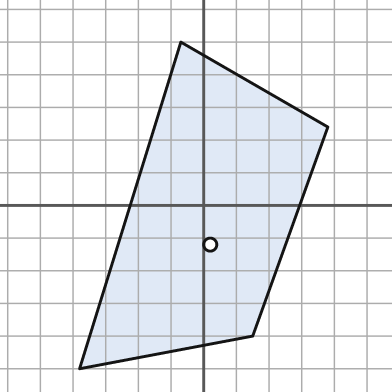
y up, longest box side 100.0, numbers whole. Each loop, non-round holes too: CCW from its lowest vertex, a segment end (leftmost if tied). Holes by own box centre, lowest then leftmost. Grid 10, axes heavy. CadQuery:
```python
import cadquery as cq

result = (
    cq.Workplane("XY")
    .moveTo(-38.0, -50.0)
    .lineTo(15.0, -40.0)
    .lineTo(38.0, 24.0)
    .lineTo(-7.0, 50.0)
    .close()
    .moveTo(2.0, -12.0)
    .circle(2.0)
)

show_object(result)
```